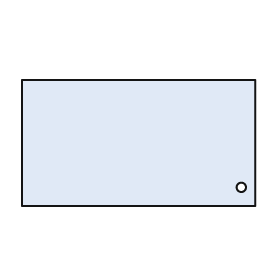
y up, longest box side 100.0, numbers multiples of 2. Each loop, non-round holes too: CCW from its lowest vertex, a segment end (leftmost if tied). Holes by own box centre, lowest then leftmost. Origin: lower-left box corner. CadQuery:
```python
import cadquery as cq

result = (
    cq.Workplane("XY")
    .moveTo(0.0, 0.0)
    .lineTo(100.0, 0.0)
    .lineTo(100.0, 54.0)
    .lineTo(0.0, 54.0)
    .close()
    .moveTo(94.0, 8.0)
    .circle(2.0)
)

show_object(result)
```